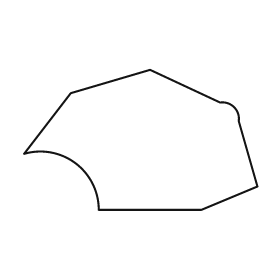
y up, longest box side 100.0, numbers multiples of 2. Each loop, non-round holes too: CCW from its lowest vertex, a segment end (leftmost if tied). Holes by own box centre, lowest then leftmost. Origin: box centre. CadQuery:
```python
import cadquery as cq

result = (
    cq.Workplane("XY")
    .moveTo(-18.0, -30.0)
    .lineTo(26.0, -30.0)
    .lineTo(50.0, -20.0)
    .lineTo(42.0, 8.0)
    .threePointArc((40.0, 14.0), (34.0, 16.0))
    .lineTo(4.0, 30.0)
    .lineTo(-30.0, 20.0)
    .lineTo(-50.0, -6.0)
    .threePointArc((-28.0, -10.0), (-18.0, -30.0))
    .close()
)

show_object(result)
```